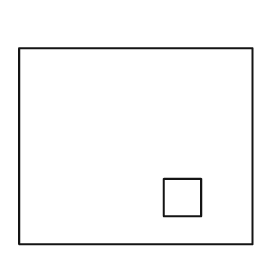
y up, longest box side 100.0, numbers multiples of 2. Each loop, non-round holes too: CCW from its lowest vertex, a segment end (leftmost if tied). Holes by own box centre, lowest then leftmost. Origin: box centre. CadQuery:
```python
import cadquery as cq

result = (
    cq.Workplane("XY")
    .moveTo(-50.0, -42.0)
    .lineTo(50.0, -42.0)
    .lineTo(50.0, 42.0)
    .lineTo(-50.0, 42.0)
    .close()
    .moveTo(12.0, -30.0)
    .lineTo(28.0, -30.0)
    .lineTo(28.0, -14.0)
    .lineTo(12.0, -14.0)
    .close()
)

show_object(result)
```